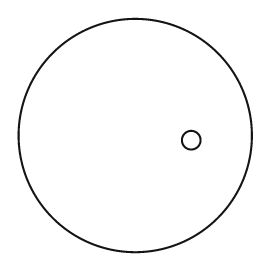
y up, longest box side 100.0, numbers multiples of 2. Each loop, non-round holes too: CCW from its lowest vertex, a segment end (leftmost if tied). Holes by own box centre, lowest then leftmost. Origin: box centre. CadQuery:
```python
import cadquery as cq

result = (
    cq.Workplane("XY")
    .moveTo(0.0, 0.0)
    .circle(50.0)
    .moveTo(24.0, -2.0)
    .circle(4.0)
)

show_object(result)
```